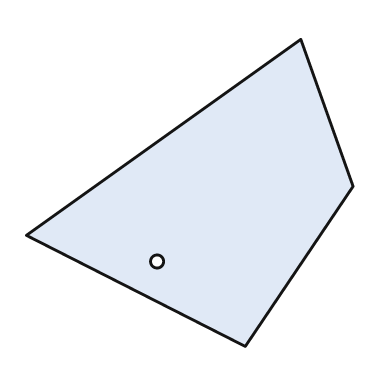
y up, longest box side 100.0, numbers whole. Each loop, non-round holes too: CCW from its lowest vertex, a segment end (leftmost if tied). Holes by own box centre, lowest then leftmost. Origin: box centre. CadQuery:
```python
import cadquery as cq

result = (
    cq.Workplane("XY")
    .moveTo(17.0, -47.0)
    .lineTo(50.0, 2.0)
    .lineTo(34.0, 47.0)
    .lineTo(-50.0, -13.0)
    .close()
    .moveTo(-10.0, -21.0)
    .circle(2.0)
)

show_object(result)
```